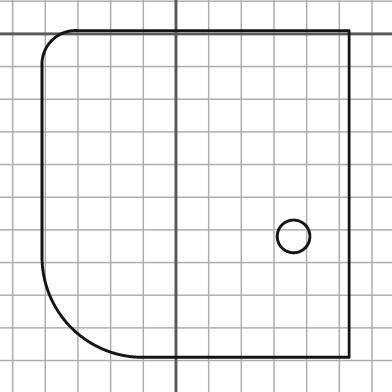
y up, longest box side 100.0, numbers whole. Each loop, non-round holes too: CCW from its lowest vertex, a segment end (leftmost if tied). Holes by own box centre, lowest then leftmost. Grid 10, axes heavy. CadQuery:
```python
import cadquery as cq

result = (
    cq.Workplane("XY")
    .moveTo(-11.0, -99.0)
    .lineTo(53.0, -99.0)
    .lineTo(53.0, 1.0)
    .lineTo(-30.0, 1.0)
    .threePointArc((-38.0, -2.0), (-41.0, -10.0))
    .lineTo(-41.0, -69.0)
    .threePointArc((-32.0, -90.0), (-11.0, -99.0))
    .close()
    .moveTo(36.0, -62.0)
    .circle(5.0)
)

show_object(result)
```